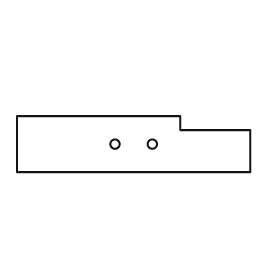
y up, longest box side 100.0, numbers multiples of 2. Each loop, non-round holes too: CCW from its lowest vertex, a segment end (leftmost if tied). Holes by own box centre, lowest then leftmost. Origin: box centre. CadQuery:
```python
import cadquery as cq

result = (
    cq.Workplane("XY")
    .moveTo(-50.0, -12.0)
    .lineTo(50.0, -12.0)
    .lineTo(50.0, 6.0)
    .lineTo(20.0, 6.0)
    .lineTo(20.0, 12.0)
    .lineTo(-50.0, 12.0)
    .close()
    .moveTo(-8.0, 0.0)
    .circle(2.0)
    .moveTo(8.0, 0.0)
    .circle(2.0)
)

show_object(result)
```